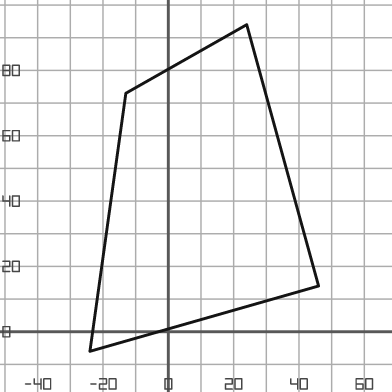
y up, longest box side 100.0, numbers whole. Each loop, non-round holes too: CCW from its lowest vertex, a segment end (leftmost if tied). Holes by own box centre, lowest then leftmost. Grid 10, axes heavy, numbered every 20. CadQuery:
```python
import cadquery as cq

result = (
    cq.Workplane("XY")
    .moveTo(-24.0, -6.0)
    .lineTo(46.0, 14.0)
    .lineTo(24.0, 94.0)
    .lineTo(-13.0, 73.0)
    .close()
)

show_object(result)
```